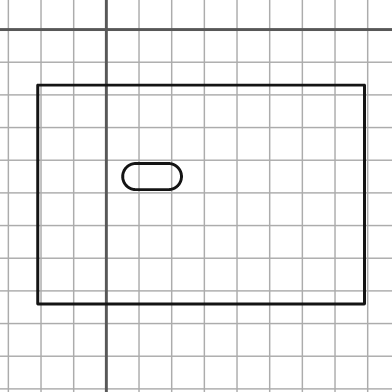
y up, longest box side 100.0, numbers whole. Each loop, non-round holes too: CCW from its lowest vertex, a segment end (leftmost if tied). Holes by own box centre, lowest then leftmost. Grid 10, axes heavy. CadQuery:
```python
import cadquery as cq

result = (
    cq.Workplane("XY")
    .moveTo(-21.0, -84.0)
    .lineTo(79.0, -84.0)
    .lineTo(79.0, -17.0)
    .lineTo(-21.0, -17.0)
    .close()
    .moveTo(9.0, -49.0)
    .lineTo(19.0, -49.0)
    .threePointArc((23.0, -45.0), (19.0, -41.0))
    .lineTo(9.0, -41.0)
    .threePointArc((5.0, -45.0), (9.0, -49.0))
    .close()
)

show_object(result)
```